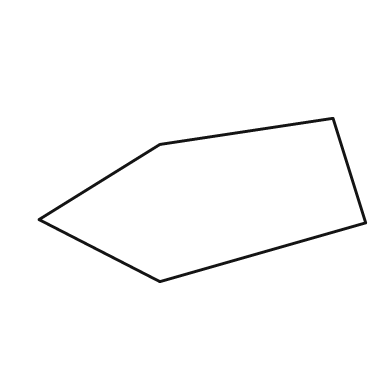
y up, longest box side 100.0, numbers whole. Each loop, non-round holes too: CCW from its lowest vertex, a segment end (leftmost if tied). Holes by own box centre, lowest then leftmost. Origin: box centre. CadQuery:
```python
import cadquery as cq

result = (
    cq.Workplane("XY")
    .moveTo(-13.0, -25.0)
    .lineTo(50.0, -7.0)
    .lineTo(40.0, 25.0)
    .lineTo(-13.0, 17.0)
    .lineTo(-50.0, -6.0)
    .close()
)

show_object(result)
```